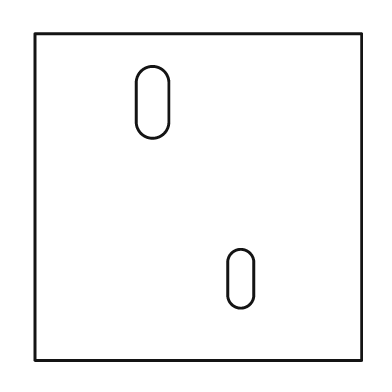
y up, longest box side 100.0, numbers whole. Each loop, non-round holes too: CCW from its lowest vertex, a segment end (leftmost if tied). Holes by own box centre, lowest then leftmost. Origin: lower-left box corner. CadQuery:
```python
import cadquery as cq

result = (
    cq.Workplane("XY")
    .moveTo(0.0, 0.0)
    .lineTo(100.0, 0.0)
    .lineTo(100.0, 100.0)
    .lineTo(0.0, 100.0)
    .close()
    .moveTo(59.0, 20.0)
    .threePointArc((63.0, 16.0), (67.0, 20.0))
    .lineTo(67.0, 30.0)
    .threePointArc((63.0, 34.0), (59.0, 30.0))
    .close()
    .moveTo(31.0, 73.0)
    .threePointArc((36.0, 68.0), (41.0, 73.0))
    .lineTo(41.0, 85.0)
    .threePointArc((36.0, 90.0), (31.0, 85.0))
    .close()
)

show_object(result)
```